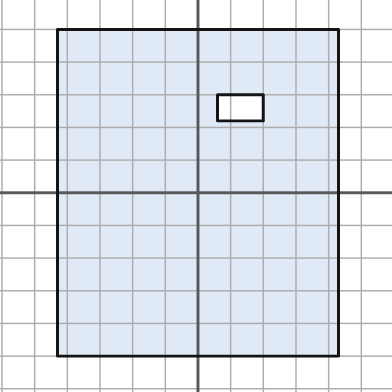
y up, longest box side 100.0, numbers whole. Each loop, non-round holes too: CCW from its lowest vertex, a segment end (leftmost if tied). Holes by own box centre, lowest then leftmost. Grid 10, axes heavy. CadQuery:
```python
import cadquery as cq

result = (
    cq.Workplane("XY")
    .moveTo(-43.0, -50.0)
    .lineTo(43.0, -50.0)
    .lineTo(43.0, 50.0)
    .lineTo(-43.0, 50.0)
    .close()
    .moveTo(6.0, 22.0)
    .lineTo(20.0, 22.0)
    .lineTo(20.0, 30.0)
    .lineTo(6.0, 30.0)
    .close()
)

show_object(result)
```